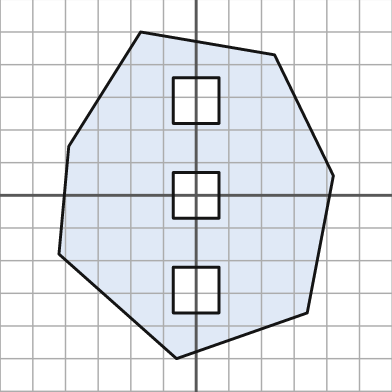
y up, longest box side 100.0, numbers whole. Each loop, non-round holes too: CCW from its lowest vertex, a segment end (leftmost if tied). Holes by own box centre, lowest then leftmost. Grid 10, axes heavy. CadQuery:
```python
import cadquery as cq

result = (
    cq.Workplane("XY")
    .moveTo(-6.0, -50.0)
    .lineTo(34.0, -36.0)
    .lineTo(42.0, 6.0)
    .lineTo(24.0, 43.0)
    .lineTo(-17.0, 50.0)
    .lineTo(-39.0, 15.0)
    .lineTo(-42.0, -18.0)
    .close()
    .moveTo(-7.0, -36.0)
    .lineTo(7.0, -36.0)
    .lineTo(7.0, -22.0)
    .lineTo(-7.0, -22.0)
    .close()
    .moveTo(-7.0, -7.0)
    .lineTo(7.0, -7.0)
    .lineTo(7.0, 7.0)
    .lineTo(-7.0, 7.0)
    .close()
    .moveTo(-7.0, 22.0)
    .lineTo(7.0, 22.0)
    .lineTo(7.0, 36.0)
    .lineTo(-7.0, 36.0)
    .close()
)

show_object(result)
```